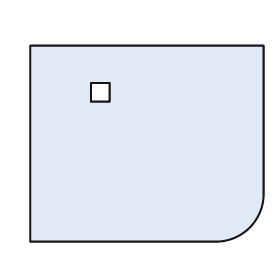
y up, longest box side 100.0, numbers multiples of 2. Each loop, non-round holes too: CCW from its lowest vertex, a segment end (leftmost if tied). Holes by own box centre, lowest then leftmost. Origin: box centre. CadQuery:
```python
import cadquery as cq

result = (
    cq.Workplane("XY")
    .moveTo(-50.0, -42.0)
    .lineTo(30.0, -42.0)
    .threePointArc((44.0, -36.0), (50.0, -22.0))
    .lineTo(50.0, 42.0)
    .lineTo(-50.0, 42.0)
    .close()
    .moveTo(-24.0, 18.0)
    .lineTo(-16.0, 18.0)
    .lineTo(-16.0, 26.0)
    .lineTo(-24.0, 26.0)
    .close()
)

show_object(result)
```